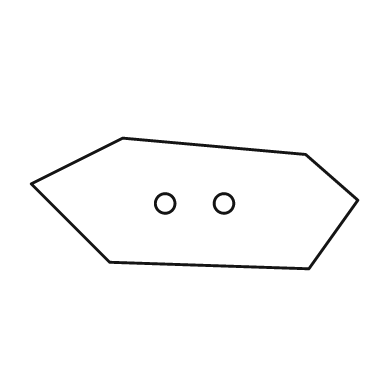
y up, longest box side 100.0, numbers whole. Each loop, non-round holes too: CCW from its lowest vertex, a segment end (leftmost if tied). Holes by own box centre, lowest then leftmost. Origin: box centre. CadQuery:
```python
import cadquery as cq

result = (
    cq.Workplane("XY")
    .moveTo(35.0, -20.0)
    .lineTo(50.0, 1.0)
    .lineTo(34.0, 15.0)
    .lineTo(-22.0, 20.0)
    .lineTo(-50.0, 6.0)
    .lineTo(-26.0, -18.0)
    .close()
    .moveTo(-9.0, 0.0)
    .circle(3.0)
    .moveTo(9.0, 0.0)
    .circle(3.0)
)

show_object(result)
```